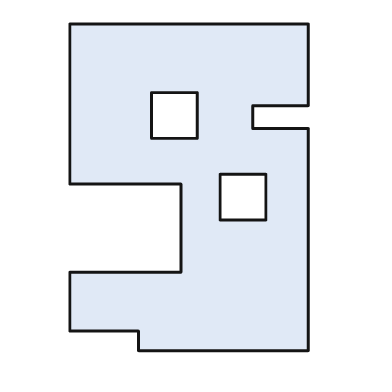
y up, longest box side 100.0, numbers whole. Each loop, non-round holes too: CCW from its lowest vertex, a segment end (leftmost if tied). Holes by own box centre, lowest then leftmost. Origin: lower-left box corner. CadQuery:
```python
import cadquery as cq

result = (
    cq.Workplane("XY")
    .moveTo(21.0, 0.0)
    .lineTo(73.0, 0.0)
    .lineTo(73.0, 68.0)
    .lineTo(56.0, 68.0)
    .lineTo(56.0, 75.0)
    .lineTo(73.0, 75.0)
    .lineTo(73.0, 100.0)
    .lineTo(0.0, 100.0)
    .lineTo(0.0, 51.0)
    .lineTo(34.0, 51.0)
    .lineTo(34.0, 24.0)
    .lineTo(0.0, 24.0)
    .lineTo(0.0, 6.0)
    .lineTo(21.0, 6.0)
    .close()
    .moveTo(46.0, 40.0)
    .lineTo(60.0, 40.0)
    .lineTo(60.0, 54.0)
    .lineTo(46.0, 54.0)
    .close()
    .moveTo(25.0, 65.0)
    .lineTo(39.0, 65.0)
    .lineTo(39.0, 79.0)
    .lineTo(25.0, 79.0)
    .close()
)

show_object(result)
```